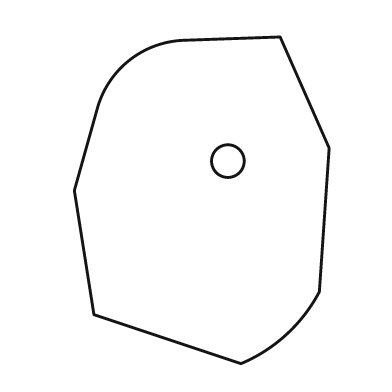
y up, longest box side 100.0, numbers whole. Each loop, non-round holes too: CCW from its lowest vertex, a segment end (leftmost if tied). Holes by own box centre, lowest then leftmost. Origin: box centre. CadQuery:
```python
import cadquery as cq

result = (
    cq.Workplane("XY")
    .moveTo(12.0, -50.0)
    .threePointArc((26.0, -41.0), (36.0, -28.0))
    .lineTo(39.0, 16.0)
    .lineTo(24.0, 50.0)
    .lineTo(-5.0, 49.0)
    .threePointArc((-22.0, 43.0), (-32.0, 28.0))
    .lineTo(-39.0, 3.0)
    .lineTo(-33.0, -35.0)
    .close()
    .moveTo(8.0, 12.0)
    .circle(5.0)
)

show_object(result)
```